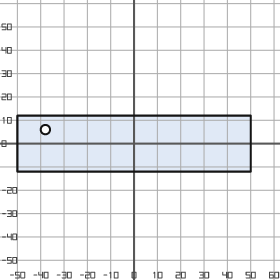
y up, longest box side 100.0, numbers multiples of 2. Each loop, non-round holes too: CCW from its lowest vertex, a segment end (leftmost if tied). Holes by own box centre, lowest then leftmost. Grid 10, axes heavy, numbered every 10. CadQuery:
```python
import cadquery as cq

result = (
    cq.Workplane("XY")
    .moveTo(-50.0, -12.0)
    .lineTo(50.0, -12.0)
    .lineTo(50.0, 12.0)
    .lineTo(-50.0, 12.0)
    .close()
    .moveTo(-38.0, 6.0)
    .circle(2.0)
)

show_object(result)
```